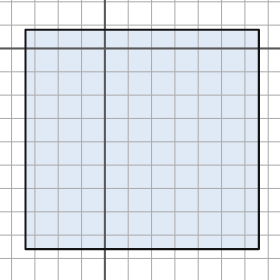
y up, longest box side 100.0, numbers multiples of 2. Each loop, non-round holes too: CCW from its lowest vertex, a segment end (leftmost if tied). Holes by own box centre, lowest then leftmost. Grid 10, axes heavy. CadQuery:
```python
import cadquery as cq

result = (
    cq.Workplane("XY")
    .moveTo(-34.0, -86.0)
    .lineTo(66.0, -86.0)
    .lineTo(66.0, 8.0)
    .lineTo(-34.0, 8.0)
    .close()
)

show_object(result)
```